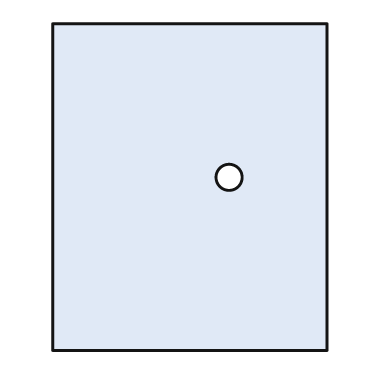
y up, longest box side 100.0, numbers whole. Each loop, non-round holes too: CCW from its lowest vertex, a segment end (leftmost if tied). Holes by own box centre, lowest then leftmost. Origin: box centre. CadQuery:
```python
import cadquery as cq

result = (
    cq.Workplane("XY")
    .moveTo(-42.0, -50.0)
    .lineTo(42.0, -50.0)
    .lineTo(42.0, 50.0)
    .lineTo(-42.0, 50.0)
    .close()
    .moveTo(12.0, 3.0)
    .circle(4.0)
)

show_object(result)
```